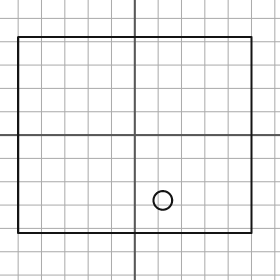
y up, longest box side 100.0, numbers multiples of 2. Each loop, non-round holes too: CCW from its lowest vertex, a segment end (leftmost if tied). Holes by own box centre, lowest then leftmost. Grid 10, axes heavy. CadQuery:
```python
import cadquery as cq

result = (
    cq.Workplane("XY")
    .moveTo(-50.0, -42.0)
    .lineTo(50.0, -42.0)
    .lineTo(50.0, 42.0)
    .lineTo(-50.0, 42.0)
    .close()
    .moveTo(12.0, -28.0)
    .circle(4.0)
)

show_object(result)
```